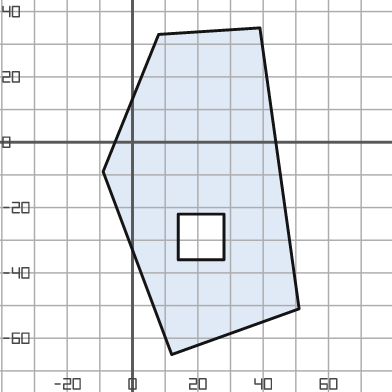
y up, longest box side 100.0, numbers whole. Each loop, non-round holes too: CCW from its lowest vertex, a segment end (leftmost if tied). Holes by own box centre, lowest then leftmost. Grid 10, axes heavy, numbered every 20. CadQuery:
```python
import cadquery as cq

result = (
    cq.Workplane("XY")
    .moveTo(12.0, -65.0)
    .lineTo(51.0, -51.0)
    .lineTo(39.0, 35.0)
    .lineTo(8.0, 33.0)
    .lineTo(-9.0, -9.0)
    .close()
    .moveTo(14.0, -36.0)
    .lineTo(28.0, -36.0)
    .lineTo(28.0, -22.0)
    .lineTo(14.0, -22.0)
    .close()
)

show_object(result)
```